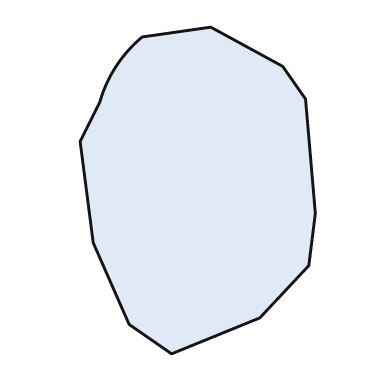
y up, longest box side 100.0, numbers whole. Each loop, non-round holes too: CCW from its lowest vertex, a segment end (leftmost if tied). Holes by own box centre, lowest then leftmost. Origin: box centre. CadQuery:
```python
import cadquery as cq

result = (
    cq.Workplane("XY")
    .moveTo(-8.0, -50.0)
    .lineTo(19.0, -39.0)
    .lineTo(34.0, -23.0)
    .lineTo(36.0, -7.0)
    .lineTo(33.0, 28.0)
    .lineTo(26.0, 38.0)
    .lineTo(4.0, 50.0)
    .lineTo(-17.0, 47.0)
    .threePointArc((-25.0, 38.0), (-30.0, 27.0))
    .lineTo(-36.0, 15.0)
    .lineTo(-32.0, -16.0)
    .lineTo(-21.0, -41.0)
    .close()
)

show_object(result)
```